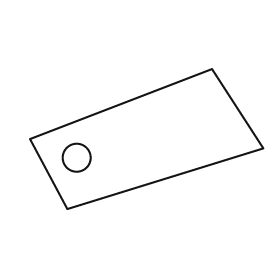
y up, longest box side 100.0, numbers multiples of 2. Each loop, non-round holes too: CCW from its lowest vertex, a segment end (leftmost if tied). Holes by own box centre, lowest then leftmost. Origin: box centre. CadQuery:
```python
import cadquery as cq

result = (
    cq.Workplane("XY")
    .moveTo(-34.0, -30.0)
    .lineTo(50.0, -4.0)
    .lineTo(28.0, 30.0)
    .lineTo(-50.0, 0.0)
    .close()
    .moveTo(-30.0, -8.0)
    .circle(6.0)
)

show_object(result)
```